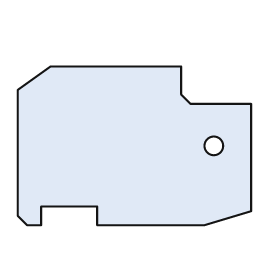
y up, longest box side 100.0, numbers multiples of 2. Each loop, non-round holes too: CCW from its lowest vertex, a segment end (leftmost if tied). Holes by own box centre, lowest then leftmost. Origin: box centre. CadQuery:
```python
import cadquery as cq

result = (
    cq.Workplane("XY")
    .moveTo(-46.0, -34.0)
    .lineTo(-40.0, -34.0)
    .lineTo(-40.0, -26.0)
    .lineTo(-16.0, -26.0)
    .lineTo(-16.0, -34.0)
    .lineTo(30.0, -34.0)
    .lineTo(50.0, -28.0)
    .lineTo(50.0, 18.0)
    .lineTo(24.0, 18.0)
    .lineTo(20.0, 22.0)
    .lineTo(20.0, 34.0)
    .lineTo(-36.0, 34.0)
    .lineTo(-50.0, 24.0)
    .lineTo(-50.0, -30.0)
    .close()
    .moveTo(34.0, 0.0)
    .circle(4.0)
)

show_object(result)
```